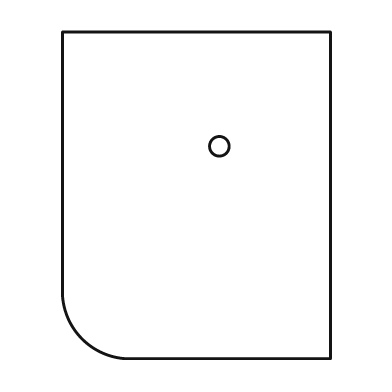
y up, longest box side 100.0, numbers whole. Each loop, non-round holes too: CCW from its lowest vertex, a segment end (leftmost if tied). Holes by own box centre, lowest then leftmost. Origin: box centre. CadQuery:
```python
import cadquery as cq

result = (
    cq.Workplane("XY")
    .moveTo(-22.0, -50.0)
    .lineTo(41.0, -50.0)
    .lineTo(41.0, 50.0)
    .lineTo(-41.0, 50.0)
    .lineTo(-41.0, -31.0)
    .threePointArc((-35.0, -44.0), (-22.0, -50.0))
    .close()
    .moveTo(7.0, 15.0)
    .circle(3.0)
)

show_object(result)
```